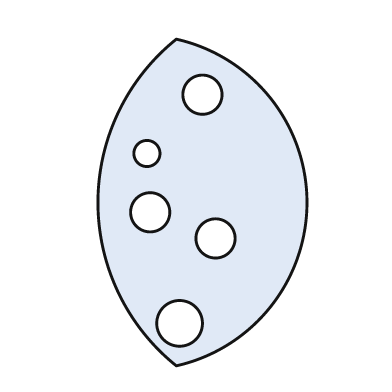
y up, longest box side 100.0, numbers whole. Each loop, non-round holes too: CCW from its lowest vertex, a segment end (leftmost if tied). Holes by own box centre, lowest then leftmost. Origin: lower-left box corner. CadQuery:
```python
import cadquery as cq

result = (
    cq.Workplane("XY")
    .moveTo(24.0, 0.0)
    .threePointArc((64.0, 50.0), (24.0, 100.0))
    .threePointArc((0.0, 50.0), (24.0, 0.0))
    .close()
    .moveTo(25.0, 13.0)
    .circle(7.0)
    .moveTo(36.0, 39.0)
    .circle(6.0)
    .moveTo(16.0, 47.0)
    .circle(6.0)
    .moveTo(15.0, 65.0)
    .circle(4.0)
    .moveTo(32.0, 83.0)
    .circle(6.0)
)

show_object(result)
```